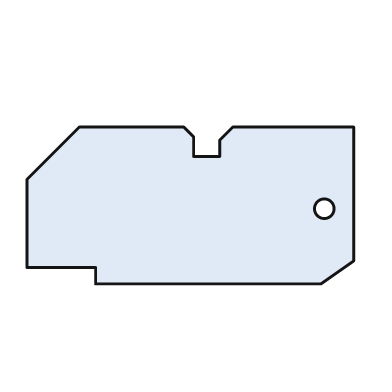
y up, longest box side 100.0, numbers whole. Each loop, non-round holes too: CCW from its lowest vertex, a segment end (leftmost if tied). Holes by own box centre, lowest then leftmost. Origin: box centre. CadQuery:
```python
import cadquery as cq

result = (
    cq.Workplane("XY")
    .moveTo(-29.0, -24.0)
    .lineTo(40.0, -24.0)
    .lineTo(50.0, -17.0)
    .lineTo(50.0, 24.0)
    .lineTo(13.0, 24.0)
    .lineTo(9.0, 20.0)
    .lineTo(9.0, 15.0)
    .lineTo(1.0, 15.0)
    .lineTo(1.0, 21.0)
    .lineTo(-2.0, 24.0)
    .lineTo(-34.0, 24.0)
    .lineTo(-50.0, 8.0)
    .lineTo(-50.0, -19.0)
    .lineTo(-29.0, -19.0)
    .close()
    .moveTo(41.0, -1.0)
    .circle(3.0)
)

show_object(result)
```